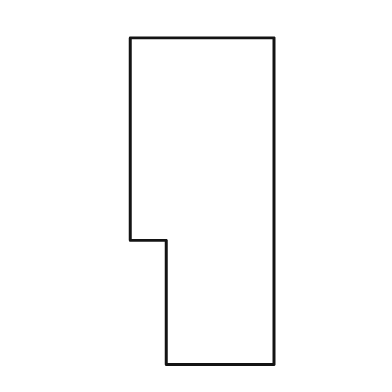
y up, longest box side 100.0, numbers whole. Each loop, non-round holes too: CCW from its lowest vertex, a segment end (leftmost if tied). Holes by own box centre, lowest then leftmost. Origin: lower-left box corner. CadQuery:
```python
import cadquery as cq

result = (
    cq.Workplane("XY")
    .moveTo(11.0, 0.0)
    .lineTo(44.0, 0.0)
    .lineTo(44.0, 100.0)
    .lineTo(0.0, 100.0)
    .lineTo(0.0, 38.0)
    .lineTo(11.0, 38.0)
    .close()
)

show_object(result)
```